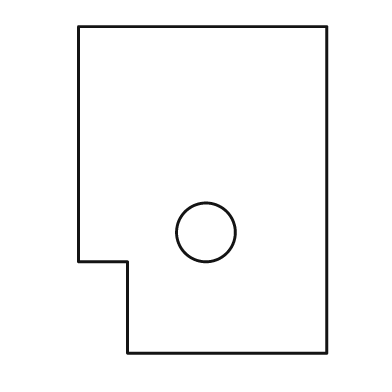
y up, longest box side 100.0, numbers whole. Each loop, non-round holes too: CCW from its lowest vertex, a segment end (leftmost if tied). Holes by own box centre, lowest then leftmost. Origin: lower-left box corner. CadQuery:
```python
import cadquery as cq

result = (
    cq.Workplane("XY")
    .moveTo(15.0, 0.0)
    .lineTo(76.0, 0.0)
    .lineTo(76.0, 100.0)
    .lineTo(0.0, 100.0)
    .lineTo(0.0, 28.0)
    .lineTo(15.0, 28.0)
    .close()
    .moveTo(39.0, 37.0)
    .circle(9.0)
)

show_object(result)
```